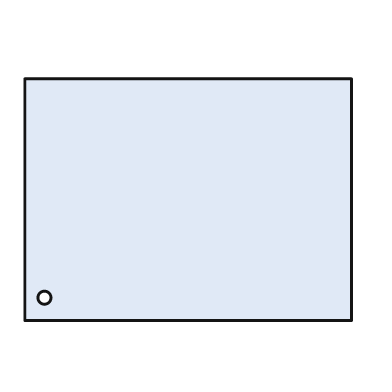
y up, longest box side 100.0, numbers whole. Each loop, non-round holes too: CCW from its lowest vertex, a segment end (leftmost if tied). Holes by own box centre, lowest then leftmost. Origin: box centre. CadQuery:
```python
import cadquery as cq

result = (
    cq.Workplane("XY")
    .moveTo(-50.0, -37.0)
    .lineTo(50.0, -37.0)
    .lineTo(50.0, 37.0)
    .lineTo(-50.0, 37.0)
    .close()
    .moveTo(-44.0, -30.0)
    .circle(2.0)
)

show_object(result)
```